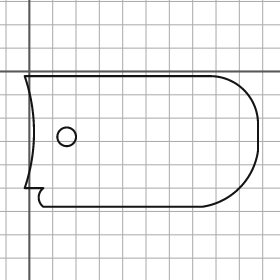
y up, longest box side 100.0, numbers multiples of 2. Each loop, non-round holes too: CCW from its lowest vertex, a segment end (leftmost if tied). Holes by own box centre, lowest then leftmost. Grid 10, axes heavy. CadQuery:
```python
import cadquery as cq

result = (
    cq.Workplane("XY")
    .moveTo(6.0, -58.0)
    .lineTo(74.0, -58.0)
    .threePointArc((90.0, -50.0), (98.0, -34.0))
    .lineTo(98.0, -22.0)
    .threePointArc((92.0, -8.0), (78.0, -2.0))
    .lineTo(-2.0, -2.0)
    .threePointArc((2.0, -26.0), (-2.0, -50.0))
    .lineTo(6.0, -50.0)
    .threePointArc((4.0, -54.0), (6.0, -58.0))
    .close()
    .moveTo(16.0, -28.0)
    .circle(4.0)
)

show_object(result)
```